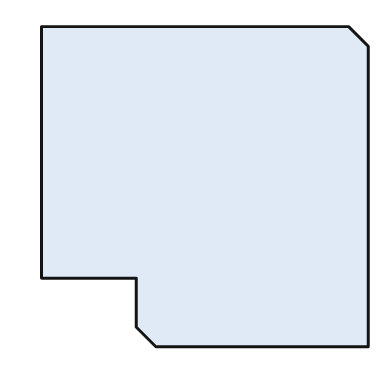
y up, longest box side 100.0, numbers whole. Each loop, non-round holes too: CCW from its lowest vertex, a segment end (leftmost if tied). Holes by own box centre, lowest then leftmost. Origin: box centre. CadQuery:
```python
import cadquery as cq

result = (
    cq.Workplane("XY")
    .moveTo(-15.0, -49.0)
    .lineTo(50.0, -49.0)
    .lineTo(50.0, 43.0)
    .lineTo(44.0, 49.0)
    .lineTo(-50.0, 49.0)
    .lineTo(-50.0, -28.0)
    .lineTo(-21.0, -28.0)
    .lineTo(-21.0, -43.0)
    .close()
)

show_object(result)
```